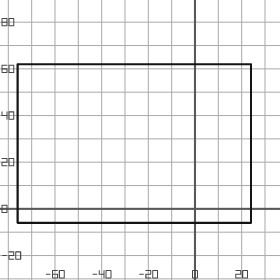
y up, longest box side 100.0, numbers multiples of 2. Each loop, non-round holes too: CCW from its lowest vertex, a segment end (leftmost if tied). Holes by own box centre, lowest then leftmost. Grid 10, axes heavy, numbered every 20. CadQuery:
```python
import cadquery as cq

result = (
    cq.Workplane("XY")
    .moveTo(-76.0, -6.0)
    .lineTo(24.0, -6.0)
    .lineTo(24.0, 62.0)
    .lineTo(-76.0, 62.0)
    .close()
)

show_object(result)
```